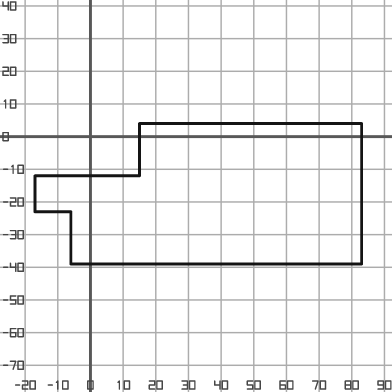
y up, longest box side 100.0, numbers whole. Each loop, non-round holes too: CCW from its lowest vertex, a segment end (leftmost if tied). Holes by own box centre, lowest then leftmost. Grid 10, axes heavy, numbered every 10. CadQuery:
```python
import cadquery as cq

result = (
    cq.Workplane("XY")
    .moveTo(-6.0, -39.0)
    .lineTo(83.0, -39.0)
    .lineTo(83.0, 4.0)
    .lineTo(15.0, 4.0)
    .lineTo(15.0, -12.0)
    .lineTo(-17.0, -12.0)
    .lineTo(-17.0, -23.0)
    .lineTo(-6.0, -23.0)
    .close()
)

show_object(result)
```